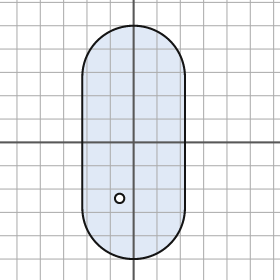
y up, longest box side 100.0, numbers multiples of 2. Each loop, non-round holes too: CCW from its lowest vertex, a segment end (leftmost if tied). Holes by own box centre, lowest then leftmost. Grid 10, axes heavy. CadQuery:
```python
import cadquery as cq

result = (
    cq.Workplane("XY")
    .moveTo(-22.0, -28.0)
    .threePointArc((0.0, -50.0), (22.0, -28.0))
    .lineTo(22.0, 28.0)
    .threePointArc((0.0, 50.0), (-22.0, 28.0))
    .close()
    .moveTo(-6.0, -24.0)
    .circle(2.0)
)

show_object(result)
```